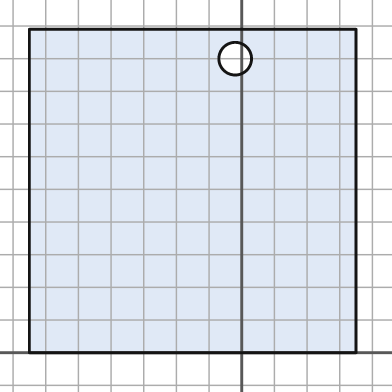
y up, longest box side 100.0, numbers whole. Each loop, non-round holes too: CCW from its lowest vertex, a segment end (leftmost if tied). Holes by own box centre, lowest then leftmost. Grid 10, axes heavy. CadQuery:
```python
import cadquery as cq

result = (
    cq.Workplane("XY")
    .moveTo(-65.0, 0.0)
    .lineTo(35.0, 0.0)
    .lineTo(35.0, 99.0)
    .lineTo(-65.0, 99.0)
    .close()
    .moveTo(-2.0, 90.0)
    .circle(5.0)
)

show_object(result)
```